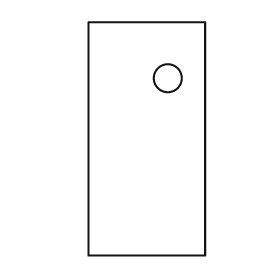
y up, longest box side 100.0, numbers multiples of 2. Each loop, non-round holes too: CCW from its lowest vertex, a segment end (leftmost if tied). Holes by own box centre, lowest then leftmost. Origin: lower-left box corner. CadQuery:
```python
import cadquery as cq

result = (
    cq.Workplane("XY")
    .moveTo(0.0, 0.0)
    .lineTo(50.0, 0.0)
    .lineTo(50.0, 100.0)
    .lineTo(0.0, 100.0)
    .close()
    .moveTo(34.0, 76.0)
    .circle(6.0)
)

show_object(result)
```